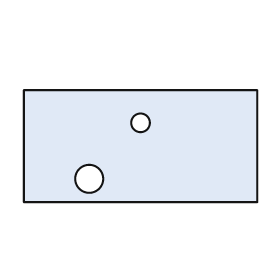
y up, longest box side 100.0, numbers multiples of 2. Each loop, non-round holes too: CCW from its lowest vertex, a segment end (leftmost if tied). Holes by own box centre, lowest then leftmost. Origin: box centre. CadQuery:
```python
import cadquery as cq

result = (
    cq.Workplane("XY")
    .moveTo(-50.0, -24.0)
    .lineTo(50.0, -24.0)
    .lineTo(50.0, 24.0)
    .lineTo(-50.0, 24.0)
    .close()
    .moveTo(-22.0, -14.0)
    .circle(6.0)
    .moveTo(0.0, 10.0)
    .circle(4.0)
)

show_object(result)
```